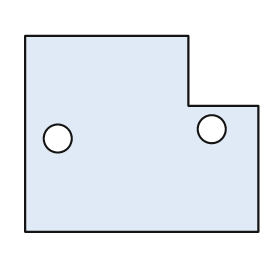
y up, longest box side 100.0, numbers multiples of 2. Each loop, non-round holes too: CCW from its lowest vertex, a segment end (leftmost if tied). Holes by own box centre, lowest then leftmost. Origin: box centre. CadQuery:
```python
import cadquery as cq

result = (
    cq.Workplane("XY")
    .moveTo(-50.0, -42.0)
    .lineTo(50.0, -42.0)
    .lineTo(50.0, 12.0)
    .lineTo(20.0, 12.0)
    .lineTo(20.0, 42.0)
    .lineTo(-50.0, 42.0)
    .close()
    .moveTo(-36.0, -2.0)
    .circle(6.0)
    .moveTo(30.0, 2.0)
    .circle(6.0)
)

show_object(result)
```